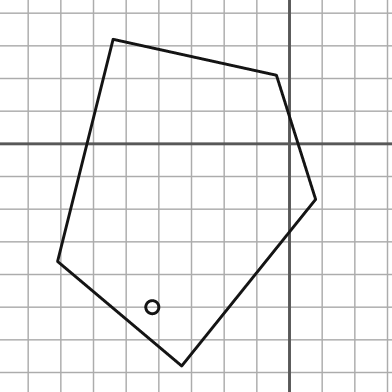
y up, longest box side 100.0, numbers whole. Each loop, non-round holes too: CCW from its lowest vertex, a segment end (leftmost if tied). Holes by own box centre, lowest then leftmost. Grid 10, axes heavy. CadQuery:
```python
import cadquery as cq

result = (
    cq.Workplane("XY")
    .moveTo(-33.0, -68.0)
    .lineTo(8.0, -17.0)
    .lineTo(-4.0, 21.0)
    .lineTo(-54.0, 32.0)
    .lineTo(-71.0, -36.0)
    .close()
    .moveTo(-42.0, -50.0)
    .circle(2.0)
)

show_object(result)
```